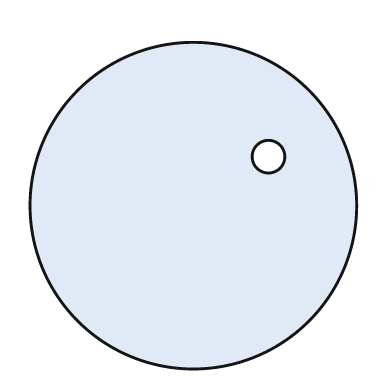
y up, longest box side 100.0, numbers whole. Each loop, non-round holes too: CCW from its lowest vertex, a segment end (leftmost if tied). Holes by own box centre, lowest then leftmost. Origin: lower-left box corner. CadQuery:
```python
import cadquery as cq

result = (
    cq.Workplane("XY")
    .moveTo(50.0, 50.0)
    .circle(50.0)
    .moveTo(73.0, 65.0)
    .circle(5.0)
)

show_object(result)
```